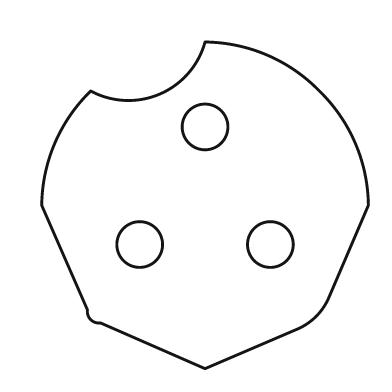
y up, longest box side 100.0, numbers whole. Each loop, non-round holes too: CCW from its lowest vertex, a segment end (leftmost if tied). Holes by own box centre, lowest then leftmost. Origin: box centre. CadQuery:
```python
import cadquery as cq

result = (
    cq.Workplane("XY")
    .moveTo(0.0, -50.0)
    .lineTo(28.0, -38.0)
    .threePointArc((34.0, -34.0), (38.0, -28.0))
    .lineTo(50.0, 0.0)
    .threePointArc((46.0, 19.0), (35.0, 35.0))
    .threePointArc((19.0, 46.0), (0.0, 50.0))
    .threePointArc((-14.0, 34.0), (-35.0, 35.0))
    .threePointArc((-46.0, 19.0), (-50.0, 0.0))
    .lineTo(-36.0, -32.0)
    .threePointArc((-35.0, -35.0), (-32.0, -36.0))
    .close()
    .moveTo(-20.0, -12.0)
    .circle(7.0)
    .moveTo(20.0, -12.0)
    .circle(7.0)
    .moveTo(0.0, 24.0)
    .circle(7.0)
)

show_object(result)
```